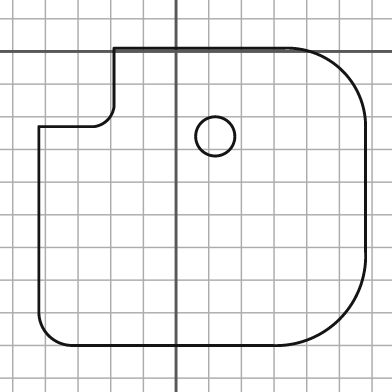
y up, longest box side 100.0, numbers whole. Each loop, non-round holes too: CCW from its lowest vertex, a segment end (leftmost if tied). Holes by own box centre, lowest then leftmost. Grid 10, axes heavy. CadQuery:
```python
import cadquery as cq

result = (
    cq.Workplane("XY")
    .moveTo(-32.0, -90.0)
    .lineTo(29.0, -90.0)
    .threePointArc((50.0, -82.0), (58.0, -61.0))
    .lineTo(58.0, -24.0)
    .threePointArc((51.0, -6.0), (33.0, 1.0))
    .lineTo(-19.0, 1.0)
    .lineTo(-19.0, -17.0)
    .threePointArc((-21.0, -21.0), (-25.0, -23.0))
    .lineTo(-42.0, -23.0)
    .lineTo(-42.0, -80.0)
    .threePointArc((-39.0, -87.0), (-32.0, -90.0))
    .close()
    .moveTo(12.0, -26.0)
    .circle(6.0)
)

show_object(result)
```